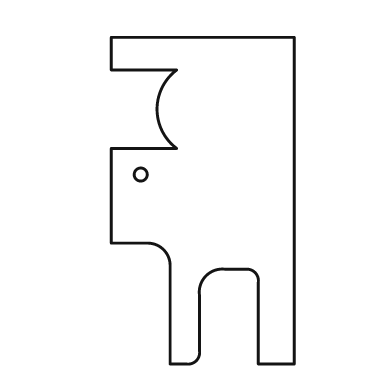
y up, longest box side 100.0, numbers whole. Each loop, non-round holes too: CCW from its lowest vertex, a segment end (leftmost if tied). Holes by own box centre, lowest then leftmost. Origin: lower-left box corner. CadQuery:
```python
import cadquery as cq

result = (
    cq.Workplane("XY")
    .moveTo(18.0, 0.0)
    .lineTo(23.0, 0.0)
    .threePointArc((26.0, 1.0), (27.0, 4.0))
    .lineTo(27.0, 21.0)
    .threePointArc((29.0, 27.0), (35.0, 29.0))
    .lineTo(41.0, 29.0)
    .threePointArc((44.0, 28.0), (45.0, 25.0))
    .lineTo(45.0, 0.0)
    .lineTo(56.0, 0.0)
    .lineTo(56.0, 100.0)
    .lineTo(0.0, 100.0)
    .lineTo(0.0, 90.0)
    .lineTo(20.0, 90.0)
    .threePointArc((14.0, 78.0), (20.0, 66.0))
    .lineTo(0.0, 66.0)
    .lineTo(0.0, 37.0)
    .lineTo(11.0, 37.0)
    .threePointArc((16.0, 35.0), (18.0, 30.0))
    .close()
    .moveTo(9.0, 58.0)
    .circle(2.0)
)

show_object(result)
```